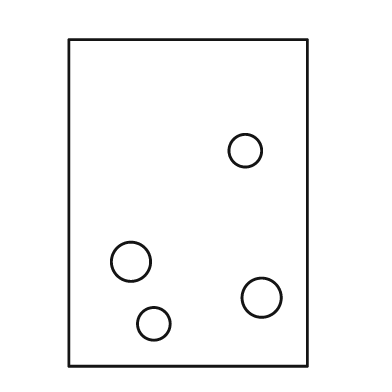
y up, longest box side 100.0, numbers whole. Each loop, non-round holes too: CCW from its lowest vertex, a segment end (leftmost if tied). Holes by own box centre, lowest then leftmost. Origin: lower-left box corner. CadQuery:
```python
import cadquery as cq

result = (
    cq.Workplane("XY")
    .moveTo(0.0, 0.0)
    .lineTo(73.0, 0.0)
    .lineTo(73.0, 100.0)
    .lineTo(0.0, 100.0)
    .close()
    .moveTo(26.0, 13.0)
    .circle(5.0)
    .moveTo(59.0, 21.0)
    .circle(6.0)
    .moveTo(19.0, 32.0)
    .circle(6.0)
    .moveTo(54.0, 66.0)
    .circle(5.0)
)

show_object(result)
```